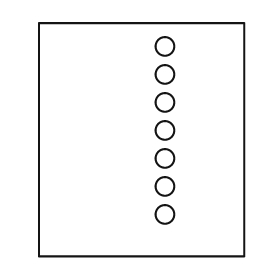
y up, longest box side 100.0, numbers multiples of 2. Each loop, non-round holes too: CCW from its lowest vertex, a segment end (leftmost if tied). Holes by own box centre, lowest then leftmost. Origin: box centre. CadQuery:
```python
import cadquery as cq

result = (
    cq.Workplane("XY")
    .moveTo(-44.0, -50.0)
    .lineTo(44.0, -50.0)
    .lineTo(44.0, 50.0)
    .lineTo(-44.0, 50.0)
    .close()
    .moveTo(10.0, -32.0)
    .circle(4.0)
    .moveTo(10.0, -20.0)
    .circle(4.0)
    .moveTo(10.0, -8.0)
    .circle(4.0)
    .moveTo(10.0, 4.0)
    .circle(4.0)
    .moveTo(10.0, 16.0)
    .circle(4.0)
    .moveTo(10.0, 28.0)
    .circle(4.0)
    .moveTo(10.0, 40.0)
    .circle(4.0)
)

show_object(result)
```